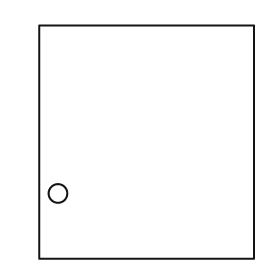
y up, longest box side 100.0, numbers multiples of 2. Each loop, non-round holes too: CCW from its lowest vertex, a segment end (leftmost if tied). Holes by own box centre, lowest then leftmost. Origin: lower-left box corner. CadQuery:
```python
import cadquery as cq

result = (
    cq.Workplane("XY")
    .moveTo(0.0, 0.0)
    .lineTo(92.0, 0.0)
    .lineTo(92.0, 100.0)
    .lineTo(0.0, 100.0)
    .close()
    .moveTo(8.0, 28.0)
    .circle(4.0)
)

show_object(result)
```